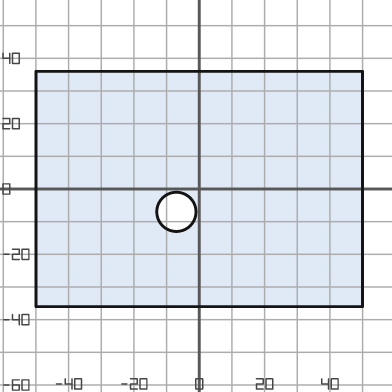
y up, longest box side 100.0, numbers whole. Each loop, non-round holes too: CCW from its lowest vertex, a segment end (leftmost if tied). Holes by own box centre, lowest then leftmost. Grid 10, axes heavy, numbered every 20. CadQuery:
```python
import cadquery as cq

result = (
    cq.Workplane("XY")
    .moveTo(-50.0, -36.0)
    .lineTo(50.0, -36.0)
    .lineTo(50.0, 36.0)
    .lineTo(-50.0, 36.0)
    .close()
    .moveTo(-7.0, -7.0)
    .circle(6.0)
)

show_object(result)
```